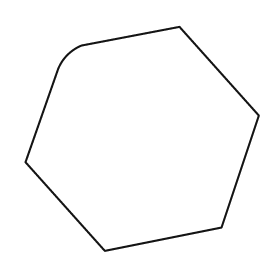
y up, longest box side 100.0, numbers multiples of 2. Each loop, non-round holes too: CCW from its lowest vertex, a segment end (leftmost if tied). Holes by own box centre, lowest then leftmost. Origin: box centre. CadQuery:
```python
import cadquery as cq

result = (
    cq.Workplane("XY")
    .moveTo(-16.0, -48.0)
    .lineTo(34.0, -38.0)
    .lineTo(50.0, 10.0)
    .lineTo(16.0, 48.0)
    .lineTo(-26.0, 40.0)
    .threePointArc((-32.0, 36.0), (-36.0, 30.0))
    .lineTo(-50.0, -10.0)
    .close()
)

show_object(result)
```